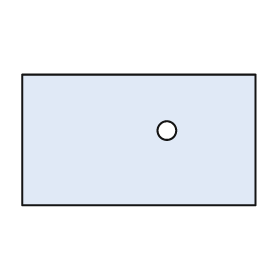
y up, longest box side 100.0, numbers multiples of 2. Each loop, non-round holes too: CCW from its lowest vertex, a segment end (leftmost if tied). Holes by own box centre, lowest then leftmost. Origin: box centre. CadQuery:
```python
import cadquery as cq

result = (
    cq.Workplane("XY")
    .moveTo(-50.0, -28.0)
    .lineTo(50.0, -28.0)
    .lineTo(50.0, 28.0)
    .lineTo(-50.0, 28.0)
    .close()
    .moveTo(12.0, 4.0)
    .circle(4.0)
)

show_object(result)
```